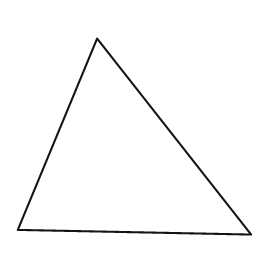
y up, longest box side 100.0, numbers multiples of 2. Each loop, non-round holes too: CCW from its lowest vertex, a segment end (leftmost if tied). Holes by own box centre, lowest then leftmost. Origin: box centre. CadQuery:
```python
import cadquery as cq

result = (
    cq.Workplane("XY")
    .moveTo(50.0, -42.0)
    .lineTo(-16.0, 42.0)
    .lineTo(-50.0, -40.0)
    .close()
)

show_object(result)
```